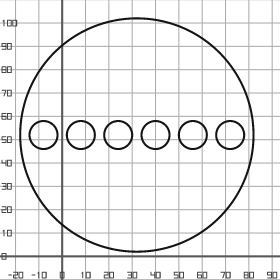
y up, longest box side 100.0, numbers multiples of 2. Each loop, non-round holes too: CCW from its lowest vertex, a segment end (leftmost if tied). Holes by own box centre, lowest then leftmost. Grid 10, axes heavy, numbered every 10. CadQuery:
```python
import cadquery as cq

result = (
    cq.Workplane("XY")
    .moveTo(32.0, 52.0)
    .circle(50.0)
    .moveTo(-8.0, 52.0)
    .circle(6.0)
    .moveTo(8.0, 52.0)
    .circle(6.0)
    .moveTo(24.0, 52.0)
    .circle(6.0)
    .moveTo(40.0, 52.0)
    .circle(6.0)
    .moveTo(56.0, 52.0)
    .circle(6.0)
    .moveTo(72.0, 52.0)
    .circle(6.0)
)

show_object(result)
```